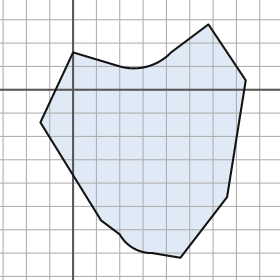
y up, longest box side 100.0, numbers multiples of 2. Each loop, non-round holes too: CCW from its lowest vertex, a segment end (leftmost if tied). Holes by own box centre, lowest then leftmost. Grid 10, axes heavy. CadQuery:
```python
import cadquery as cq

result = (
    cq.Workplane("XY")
    .moveTo(46.0, -72.0)
    .lineTo(66.0, -46.0)
    .lineTo(74.0, 4.0)
    .lineTo(58.0, 28.0)
    .lineTo(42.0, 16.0)
    .threePointArc((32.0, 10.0), (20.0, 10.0))
    .lineTo(0.0, 16.0)
    .lineTo(-14.0, -14.0)
    .lineTo(12.0, -56.0)
    .lineTo(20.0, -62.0)
    .threePointArc((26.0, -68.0), (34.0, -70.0))
    .close()
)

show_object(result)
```